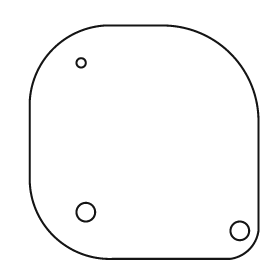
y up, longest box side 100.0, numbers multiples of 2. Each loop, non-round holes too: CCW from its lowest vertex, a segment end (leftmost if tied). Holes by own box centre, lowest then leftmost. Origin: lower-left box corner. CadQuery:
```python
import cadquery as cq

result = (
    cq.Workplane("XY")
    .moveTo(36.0, 0.0)
    .lineTo(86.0, 0.0)
    .threePointArc((94.0, 4.0), (98.0, 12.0))
    .lineTo(98.0, 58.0)
    .threePointArc((86.0, 88.0), (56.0, 100.0))
    .lineTo(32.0, 100.0)
    .threePointArc((10.0, 90.0), (0.0, 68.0))
    .lineTo(0.0, 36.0)
    .threePointArc((10.0, 10.0), (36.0, 0.0))
    .close()
    .moveTo(90.0, 12.0)
    .circle(4.0)
    .moveTo(24.0, 20.0)
    .circle(4.0)
    .moveTo(22.0, 84.0)
    .circle(2.0)
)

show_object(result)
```